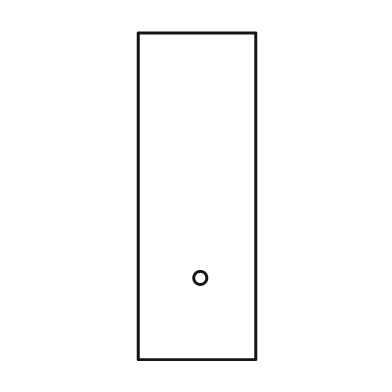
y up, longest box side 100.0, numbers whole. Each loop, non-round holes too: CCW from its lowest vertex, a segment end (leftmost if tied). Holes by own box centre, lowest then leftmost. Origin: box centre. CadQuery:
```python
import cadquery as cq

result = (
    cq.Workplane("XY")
    .moveTo(-18.0, -50.0)
    .lineTo(18.0, -50.0)
    .lineTo(18.0, 50.0)
    .lineTo(-18.0, 50.0)
    .close()
    .moveTo(1.0, -25.0)
    .circle(2.0)
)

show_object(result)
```